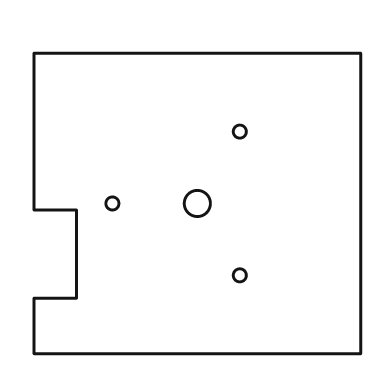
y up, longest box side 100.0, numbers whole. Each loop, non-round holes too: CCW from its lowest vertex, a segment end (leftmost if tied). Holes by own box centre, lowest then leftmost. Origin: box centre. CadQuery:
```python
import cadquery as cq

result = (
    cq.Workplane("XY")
    .moveTo(-50.0, -46.0)
    .lineTo(50.0, -46.0)
    .lineTo(50.0, 46.0)
    .lineTo(-50.0, 46.0)
    .lineTo(-50.0, -2.0)
    .lineTo(-37.0, -2.0)
    .lineTo(-37.0, -29.0)
    .lineTo(-50.0, -29.0)
    .close()
    .moveTo(13.0, -22.0)
    .circle(2.0)
    .moveTo(-26.0, 0.0)
    .circle(2.0)
    .moveTo(0.0, 0.0)
    .circle(4.0)
    .moveTo(13.0, 22.0)
    .circle(2.0)
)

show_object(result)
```